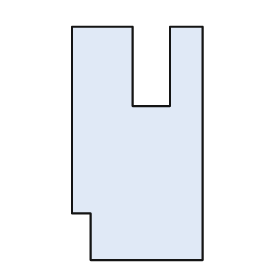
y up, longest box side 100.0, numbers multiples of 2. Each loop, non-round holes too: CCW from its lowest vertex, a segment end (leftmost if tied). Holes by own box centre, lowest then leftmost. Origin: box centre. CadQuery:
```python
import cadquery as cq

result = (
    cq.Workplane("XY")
    .moveTo(-20.0, -50.0)
    .lineTo(28.0, -50.0)
    .lineTo(28.0, 50.0)
    .lineTo(14.0, 50.0)
    .lineTo(14.0, 16.0)
    .lineTo(-2.0, 16.0)
    .lineTo(-2.0, 50.0)
    .lineTo(-28.0, 50.0)
    .lineTo(-28.0, -30.0)
    .lineTo(-20.0, -30.0)
    .close()
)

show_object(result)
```